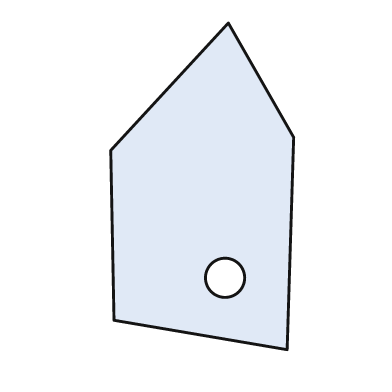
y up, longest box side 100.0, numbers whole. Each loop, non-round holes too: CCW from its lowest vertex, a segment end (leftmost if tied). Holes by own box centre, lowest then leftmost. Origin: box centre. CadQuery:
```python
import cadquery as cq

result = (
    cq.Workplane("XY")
    .moveTo(26.0, -50.0)
    .lineTo(28.0, 15.0)
    .lineTo(8.0, 50.0)
    .lineTo(-28.0, 11.0)
    .lineTo(-27.0, -41.0)
    .close()
    .moveTo(7.0, -28.0)
    .circle(6.0)
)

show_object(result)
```